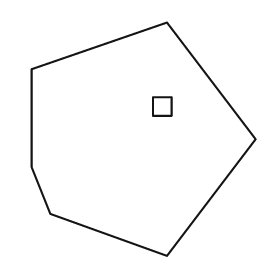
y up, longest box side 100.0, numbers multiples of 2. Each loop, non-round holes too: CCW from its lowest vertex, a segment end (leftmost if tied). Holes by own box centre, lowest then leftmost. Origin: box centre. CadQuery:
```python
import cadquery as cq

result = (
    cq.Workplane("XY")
    .moveTo(10.0, -50.0)
    .lineTo(48.0, 0.0)
    .lineTo(10.0, 50.0)
    .lineTo(-48.0, 30.0)
    .lineTo(-48.0, -12.0)
    .lineTo(-40.0, -32.0)
    .close()
    .moveTo(4.0, 10.0)
    .lineTo(12.0, 10.0)
    .lineTo(12.0, 18.0)
    .lineTo(4.0, 18.0)
    .close()
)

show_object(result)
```